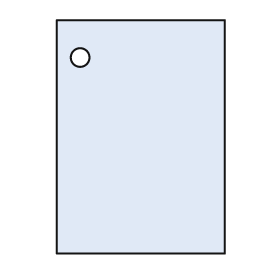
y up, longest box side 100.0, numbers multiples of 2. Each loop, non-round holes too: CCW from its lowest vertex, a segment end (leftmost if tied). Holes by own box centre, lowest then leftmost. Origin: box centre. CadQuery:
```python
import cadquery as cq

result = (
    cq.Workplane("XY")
    .moveTo(-36.0, -50.0)
    .lineTo(36.0, -50.0)
    .lineTo(36.0, 50.0)
    .lineTo(-36.0, 50.0)
    .close()
    .moveTo(-26.0, 34.0)
    .circle(4.0)
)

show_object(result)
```